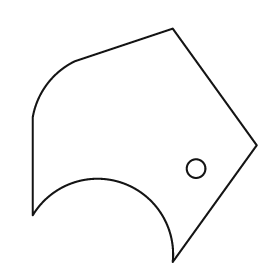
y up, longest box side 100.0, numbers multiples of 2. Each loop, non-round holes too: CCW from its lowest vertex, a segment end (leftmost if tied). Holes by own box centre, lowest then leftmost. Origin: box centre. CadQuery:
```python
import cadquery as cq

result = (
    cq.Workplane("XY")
    .moveTo(12.0, -50.0)
    .lineTo(48.0, 0.0)
    .lineTo(12.0, 50.0)
    .lineTo(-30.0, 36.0)
    .threePointArc((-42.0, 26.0), (-48.0, 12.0))
    .lineTo(-48.0, -30.0)
    .threePointArc((-10.0, -16.0), (12.0, -50.0))
    .close()
    .moveTo(22.0, -10.0)
    .circle(4.0)
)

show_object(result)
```